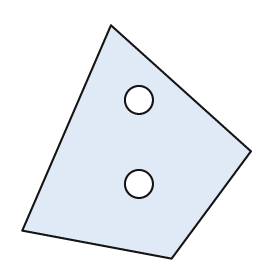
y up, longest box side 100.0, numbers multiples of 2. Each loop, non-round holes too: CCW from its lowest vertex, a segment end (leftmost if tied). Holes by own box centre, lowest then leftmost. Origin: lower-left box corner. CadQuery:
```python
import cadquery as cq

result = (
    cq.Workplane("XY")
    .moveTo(64.0, 0.0)
    .lineTo(98.0, 46.0)
    .lineTo(38.0, 100.0)
    .lineTo(0.0, 12.0)
    .close()
    .moveTo(50.0, 32.0)
    .circle(6.0)
    .moveTo(50.0, 68.0)
    .circle(6.0)
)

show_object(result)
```